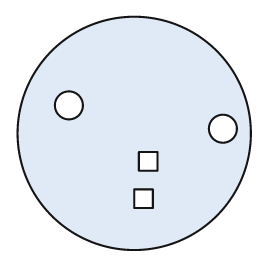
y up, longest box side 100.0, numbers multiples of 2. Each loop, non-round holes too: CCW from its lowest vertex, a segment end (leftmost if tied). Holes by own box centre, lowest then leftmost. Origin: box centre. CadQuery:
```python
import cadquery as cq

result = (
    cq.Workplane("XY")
    .moveTo(0.0, 0.0)
    .circle(50.0)
    .moveTo(0.0, -32.0)
    .lineTo(8.0, -32.0)
    .lineTo(8.0, -24.0)
    .lineTo(0.0, -24.0)
    .close()
    .moveTo(2.0, -16.0)
    .lineTo(10.0, -16.0)
    .lineTo(10.0, -8.0)
    .lineTo(2.0, -8.0)
    .close()
    .moveTo(38.0, 2.0)
    .circle(6.0)
    .moveTo(-28.0, 12.0)
    .circle(6.0)
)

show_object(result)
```